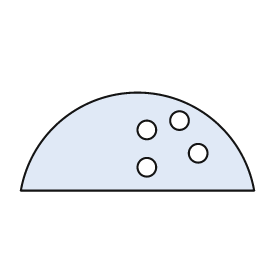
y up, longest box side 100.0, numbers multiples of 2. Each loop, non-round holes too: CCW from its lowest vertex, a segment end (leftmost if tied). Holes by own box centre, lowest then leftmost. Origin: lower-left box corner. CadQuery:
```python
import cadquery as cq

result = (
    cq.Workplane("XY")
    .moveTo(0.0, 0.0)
    .lineTo(100.0, 0.0)
    .threePointArc((50.0, 42.0), (0.0, 0.0))
    .close()
    .moveTo(54.0, 10.0)
    .circle(4.0)
    .moveTo(76.0, 16.0)
    .circle(4.0)
    .moveTo(54.0, 26.0)
    .circle(4.0)
    .moveTo(68.0, 30.0)
    .circle(4.0)
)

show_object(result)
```